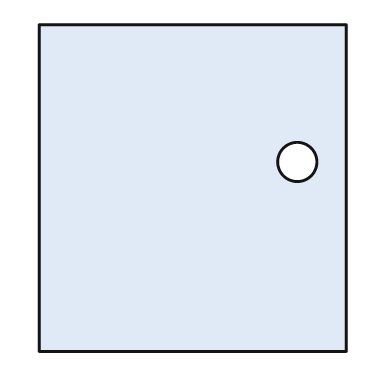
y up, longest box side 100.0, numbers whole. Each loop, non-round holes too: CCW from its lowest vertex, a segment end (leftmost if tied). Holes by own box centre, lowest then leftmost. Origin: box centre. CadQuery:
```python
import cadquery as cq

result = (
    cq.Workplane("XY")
    .moveTo(-47.0, -50.0)
    .lineTo(47.0, -50.0)
    .lineTo(47.0, 50.0)
    .lineTo(-47.0, 50.0)
    .close()
    .moveTo(32.0, 8.0)
    .circle(6.0)
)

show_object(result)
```